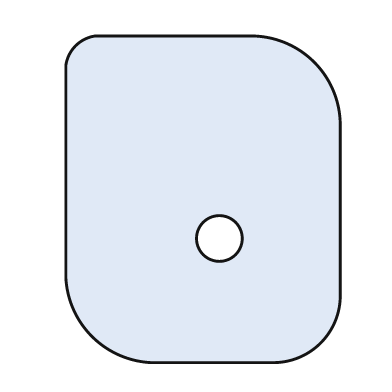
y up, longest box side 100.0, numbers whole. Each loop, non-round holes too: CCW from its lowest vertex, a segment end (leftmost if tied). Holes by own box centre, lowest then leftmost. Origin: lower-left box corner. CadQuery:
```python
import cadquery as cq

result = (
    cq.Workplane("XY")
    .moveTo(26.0, 0.0)
    .lineTo(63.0, 0.0)
    .threePointArc((78.0, 6.0), (84.0, 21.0))
    .lineTo(84.0, 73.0)
    .threePointArc((76.0, 92.0), (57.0, 100.0))
    .lineTo(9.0, 100.0)
    .threePointArc((3.0, 97.0), (0.0, 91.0))
    .lineTo(0.0, 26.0)
    .threePointArc((8.0, 8.0), (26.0, 0.0))
    .close()
    .moveTo(47.0, 38.0)
    .circle(7.0)
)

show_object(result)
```